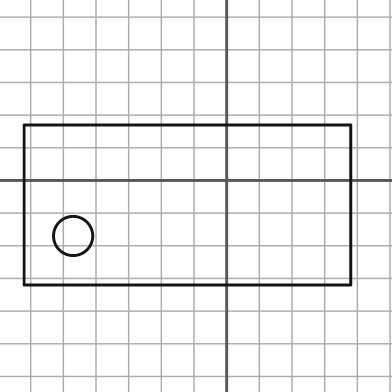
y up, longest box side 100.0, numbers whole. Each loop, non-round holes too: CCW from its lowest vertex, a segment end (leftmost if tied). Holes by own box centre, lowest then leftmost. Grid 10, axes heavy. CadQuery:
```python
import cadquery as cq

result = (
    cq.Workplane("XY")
    .moveTo(-62.0, -32.0)
    .lineTo(38.0, -32.0)
    .lineTo(38.0, 17.0)
    .lineTo(-62.0, 17.0)
    .close()
    .moveTo(-47.0, -17.0)
    .circle(6.0)
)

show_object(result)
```